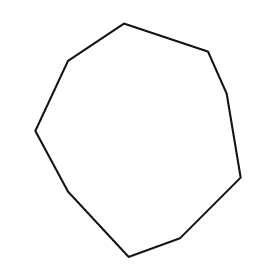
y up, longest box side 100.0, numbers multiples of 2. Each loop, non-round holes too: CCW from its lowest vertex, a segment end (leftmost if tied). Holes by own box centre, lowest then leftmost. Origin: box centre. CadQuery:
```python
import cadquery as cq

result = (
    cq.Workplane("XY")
    .moveTo(-4.0, -50.0)
    .lineTo(18.0, -42.0)
    .lineTo(44.0, -16.0)
    .lineTo(38.0, 20.0)
    .lineTo(30.0, 38.0)
    .lineTo(-6.0, 50.0)
    .lineTo(-30.0, 34.0)
    .lineTo(-44.0, 4.0)
    .lineTo(-30.0, -22.0)
    .close()
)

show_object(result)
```